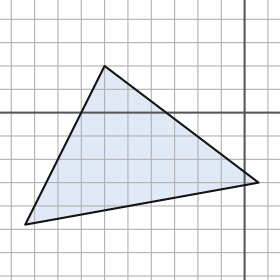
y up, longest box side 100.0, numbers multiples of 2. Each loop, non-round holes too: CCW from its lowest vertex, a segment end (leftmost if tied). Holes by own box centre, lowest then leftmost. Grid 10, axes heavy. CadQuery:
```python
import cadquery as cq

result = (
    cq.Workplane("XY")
    .moveTo(-94.0, -48.0)
    .lineTo(6.0, -30.0)
    .lineTo(-60.0, 20.0)
    .close()
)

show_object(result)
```